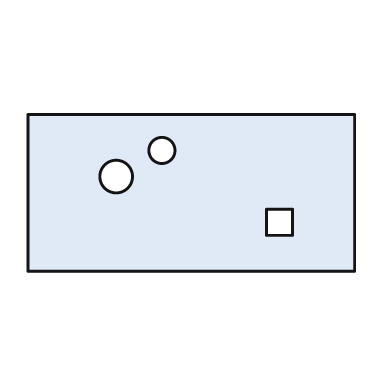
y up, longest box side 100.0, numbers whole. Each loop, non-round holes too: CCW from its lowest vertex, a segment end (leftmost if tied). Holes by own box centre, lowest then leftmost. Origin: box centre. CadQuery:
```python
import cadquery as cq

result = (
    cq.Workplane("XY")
    .moveTo(-50.0, -24.0)
    .lineTo(50.0, -24.0)
    .lineTo(50.0, 24.0)
    .lineTo(-50.0, 24.0)
    .close()
    .moveTo(23.0, -13.0)
    .lineTo(31.0, -13.0)
    .lineTo(31.0, -5.0)
    .lineTo(23.0, -5.0)
    .close()
    .moveTo(-23.0, 5.0)
    .circle(5.0)
    .moveTo(-9.0, 13.0)
    .circle(4.0)
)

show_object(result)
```